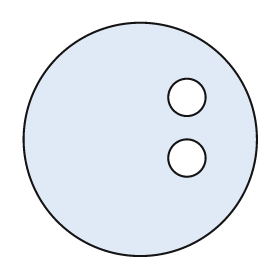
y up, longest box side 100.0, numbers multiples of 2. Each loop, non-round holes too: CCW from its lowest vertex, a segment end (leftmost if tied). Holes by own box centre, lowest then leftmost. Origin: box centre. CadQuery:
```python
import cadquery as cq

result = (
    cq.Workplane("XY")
    .moveTo(0.0, 0.0)
    .circle(50.0)
    .moveTo(20.0, -8.0)
    .circle(8.0)
    .moveTo(20.0, 18.0)
    .circle(8.0)
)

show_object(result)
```